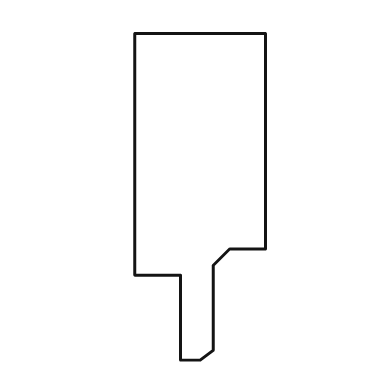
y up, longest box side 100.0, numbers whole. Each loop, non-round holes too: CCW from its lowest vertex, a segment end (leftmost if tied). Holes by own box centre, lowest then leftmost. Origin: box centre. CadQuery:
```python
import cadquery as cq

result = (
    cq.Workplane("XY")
    .moveTo(-6.0, -50.0)
    .lineTo(0.0, -50.0)
    .lineTo(4.0, -47.0)
    .lineTo(4.0, -21.0)
    .lineTo(9.0, -16.0)
    .lineTo(20.0, -16.0)
    .lineTo(20.0, 50.0)
    .lineTo(-20.0, 50.0)
    .lineTo(-20.0, -24.0)
    .lineTo(-6.0, -24.0)
    .close()
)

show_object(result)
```